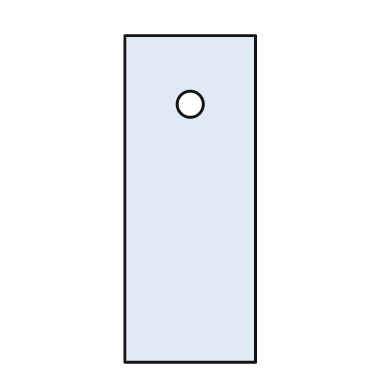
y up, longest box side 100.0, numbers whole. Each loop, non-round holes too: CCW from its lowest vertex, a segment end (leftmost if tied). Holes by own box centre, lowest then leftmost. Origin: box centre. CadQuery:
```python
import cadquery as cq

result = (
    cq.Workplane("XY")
    .moveTo(-20.0, -50.0)
    .lineTo(20.0, -50.0)
    .lineTo(20.0, 50.0)
    .lineTo(-20.0, 50.0)
    .close()
    .moveTo(0.0, 29.0)
    .circle(4.0)
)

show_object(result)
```